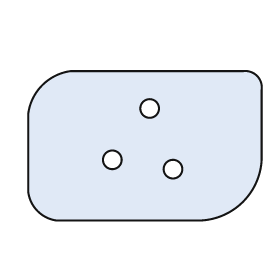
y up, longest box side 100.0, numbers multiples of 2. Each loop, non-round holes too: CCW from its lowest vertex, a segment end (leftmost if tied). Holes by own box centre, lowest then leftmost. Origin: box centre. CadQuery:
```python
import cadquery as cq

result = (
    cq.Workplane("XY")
    .moveTo(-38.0, -32.0)
    .lineTo(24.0, -32.0)
    .threePointArc((42.0, -24.0), (50.0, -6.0))
    .lineTo(50.0, 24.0)
    .threePointArc((48.0, 30.0), (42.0, 32.0))
    .lineTo(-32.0, 32.0)
    .threePointArc((-44.0, 26.0), (-50.0, 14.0))
    .lineTo(-50.0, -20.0)
    .threePointArc((-46.0, -28.0), (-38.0, -32.0))
    .close()
    .moveTo(12.0, -10.0)
    .circle(4.0)
    .moveTo(-14.0, -6.0)
    .circle(4.0)
    .moveTo(2.0, 16.0)
    .circle(4.0)
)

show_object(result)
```